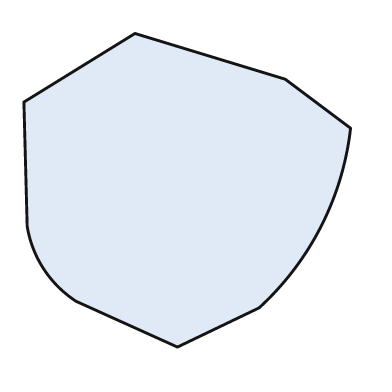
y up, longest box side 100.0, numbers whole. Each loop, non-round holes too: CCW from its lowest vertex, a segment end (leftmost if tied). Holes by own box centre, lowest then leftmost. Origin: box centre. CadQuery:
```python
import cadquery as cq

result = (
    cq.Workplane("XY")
    .moveTo(-3.0, -48.0)
    .lineTo(22.0, -36.0)
    .threePointArc((41.0, -11.0), (50.0, 19.0))
    .lineTo(30.0, 34.0)
    .lineTo(-16.0, 48.0)
    .lineTo(-50.0, 27.0)
    .lineTo(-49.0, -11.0)
    .threePointArc((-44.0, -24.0), (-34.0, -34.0))
    .close()
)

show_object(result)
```